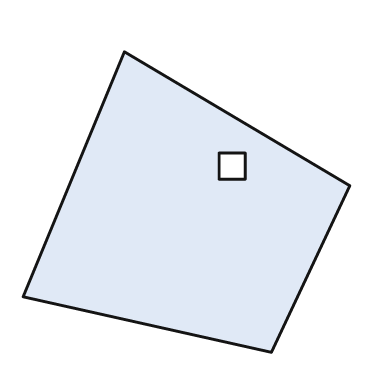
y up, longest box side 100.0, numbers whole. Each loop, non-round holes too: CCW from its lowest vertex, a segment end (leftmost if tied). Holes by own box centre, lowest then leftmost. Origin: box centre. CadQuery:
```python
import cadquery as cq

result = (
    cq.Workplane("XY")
    .moveTo(26.0, -46.0)
    .lineTo(50.0, 5.0)
    .lineTo(-19.0, 46.0)
    .lineTo(-50.0, -29.0)
    .close()
    .moveTo(10.0, 7.0)
    .lineTo(18.0, 7.0)
    .lineTo(18.0, 15.0)
    .lineTo(10.0, 15.0)
    .close()
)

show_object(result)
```